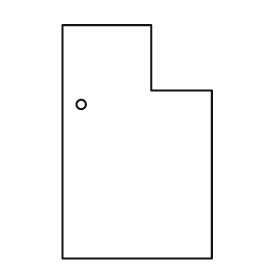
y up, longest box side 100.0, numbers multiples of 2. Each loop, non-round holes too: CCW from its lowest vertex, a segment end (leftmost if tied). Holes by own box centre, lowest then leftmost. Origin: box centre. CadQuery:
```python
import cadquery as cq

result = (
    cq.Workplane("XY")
    .moveTo(-32.0, -50.0)
    .lineTo(32.0, -50.0)
    .lineTo(32.0, 22.0)
    .lineTo(6.0, 22.0)
    .lineTo(6.0, 50.0)
    .lineTo(-32.0, 50.0)
    .close()
    .moveTo(-24.0, 16.0)
    .circle(2.0)
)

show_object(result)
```